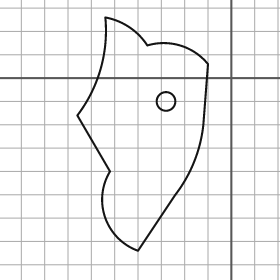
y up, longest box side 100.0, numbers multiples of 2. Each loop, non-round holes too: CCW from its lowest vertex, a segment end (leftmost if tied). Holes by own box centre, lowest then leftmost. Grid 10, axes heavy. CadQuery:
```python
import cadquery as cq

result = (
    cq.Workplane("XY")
    .moveTo(-40.0, -74.0)
    .lineTo(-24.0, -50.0)
    .threePointArc((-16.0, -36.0), (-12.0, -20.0))
    .lineTo(-10.0, 6.0)
    .threePointArc((-22.0, 14.0), (-36.0, 14.0))
    .threePointArc((-44.0, 22.0), (-54.0, 26.0))
    .threePointArc((-56.0, 4.0), (-66.0, -16.0))
    .lineTo(-52.0, -40.0)
    .threePointArc((-54.0, -60.0), (-40.0, -74.0))
    .close()
    .moveTo(-28.0, -10.0)
    .circle(4.0)
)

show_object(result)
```